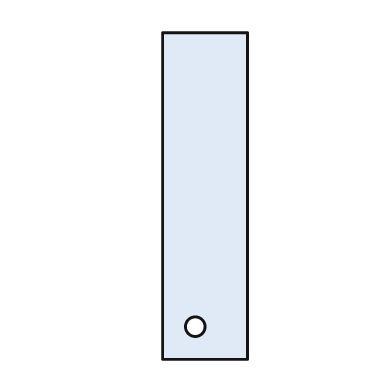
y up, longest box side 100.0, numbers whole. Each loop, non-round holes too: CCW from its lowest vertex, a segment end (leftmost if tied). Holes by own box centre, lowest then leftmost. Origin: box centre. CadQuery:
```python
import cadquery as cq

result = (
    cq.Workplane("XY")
    .moveTo(-13.0, -50.0)
    .lineTo(13.0, -50.0)
    .lineTo(13.0, 50.0)
    .lineTo(-13.0, 50.0)
    .close()
    .moveTo(-3.0, -40.0)
    .circle(3.0)
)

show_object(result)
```